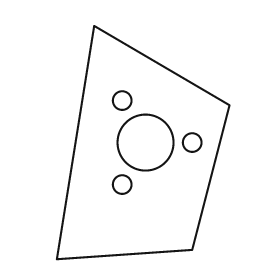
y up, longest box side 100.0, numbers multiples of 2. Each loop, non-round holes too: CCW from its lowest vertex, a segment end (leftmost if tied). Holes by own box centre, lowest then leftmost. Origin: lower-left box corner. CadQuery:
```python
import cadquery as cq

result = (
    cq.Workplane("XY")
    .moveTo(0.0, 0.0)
    .lineTo(58.0, 4.0)
    .lineTo(74.0, 66.0)
    .lineTo(16.0, 100.0)
    .close()
    .moveTo(28.0, 32.0)
    .circle(4.0)
    .moveTo(38.0, 50.0)
    .circle(12.0)
    .moveTo(58.0, 50.0)
    .circle(4.0)
    .moveTo(28.0, 68.0)
    .circle(4.0)
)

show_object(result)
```